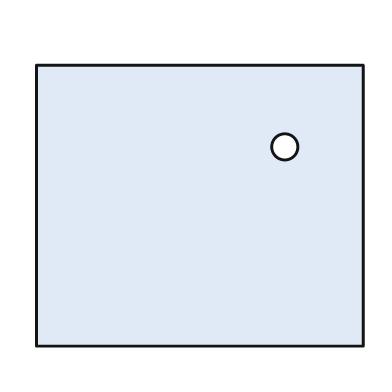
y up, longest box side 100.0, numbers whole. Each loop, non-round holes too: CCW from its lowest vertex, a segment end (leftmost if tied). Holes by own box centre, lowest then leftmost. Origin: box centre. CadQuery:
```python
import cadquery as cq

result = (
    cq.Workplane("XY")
    .moveTo(-50.0, -43.0)
    .lineTo(50.0, -43.0)
    .lineTo(50.0, 43.0)
    .lineTo(-50.0, 43.0)
    .close()
    .moveTo(26.0, 18.0)
    .circle(4.0)
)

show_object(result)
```